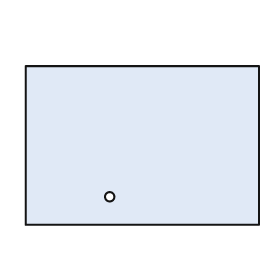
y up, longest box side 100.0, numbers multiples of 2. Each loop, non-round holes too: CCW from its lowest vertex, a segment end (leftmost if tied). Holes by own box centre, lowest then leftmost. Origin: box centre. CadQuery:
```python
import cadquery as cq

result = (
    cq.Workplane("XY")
    .moveTo(-50.0, -34.0)
    .lineTo(50.0, -34.0)
    .lineTo(50.0, 34.0)
    .lineTo(-50.0, 34.0)
    .close()
    .moveTo(-14.0, -22.0)
    .circle(2.0)
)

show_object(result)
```